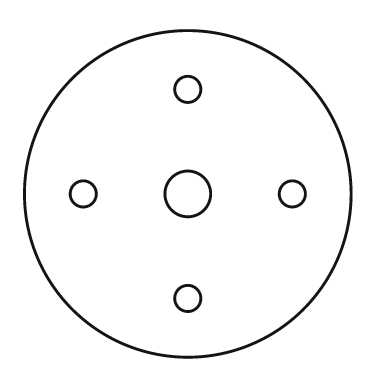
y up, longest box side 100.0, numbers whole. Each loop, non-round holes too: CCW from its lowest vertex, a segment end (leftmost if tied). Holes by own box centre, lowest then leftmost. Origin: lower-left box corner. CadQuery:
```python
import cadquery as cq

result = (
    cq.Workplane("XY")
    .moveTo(50.0, 50.0)
    .circle(50.0)
    .moveTo(50.0, 18.0)
    .circle(4.0)
    .moveTo(18.0, 50.0)
    .circle(4.0)
    .moveTo(50.0, 50.0)
    .circle(7.0)
    .moveTo(82.0, 50.0)
    .circle(4.0)
    .moveTo(50.0, 82.0)
    .circle(4.0)
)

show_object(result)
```